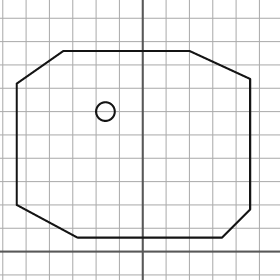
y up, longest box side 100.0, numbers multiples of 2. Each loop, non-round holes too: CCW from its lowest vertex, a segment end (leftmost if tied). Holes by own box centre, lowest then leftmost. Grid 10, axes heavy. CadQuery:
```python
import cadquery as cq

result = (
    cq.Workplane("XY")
    .moveTo(-28.0, 6.0)
    .lineTo(34.0, 6.0)
    .lineTo(46.0, 18.0)
    .lineTo(46.0, 74.0)
    .lineTo(20.0, 86.0)
    .lineTo(-34.0, 86.0)
    .lineTo(-54.0, 72.0)
    .lineTo(-54.0, 20.0)
    .close()
    .moveTo(-16.0, 60.0)
    .circle(4.0)
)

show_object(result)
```